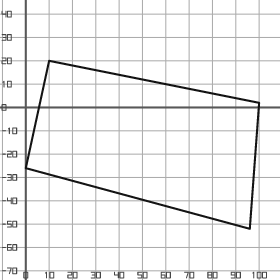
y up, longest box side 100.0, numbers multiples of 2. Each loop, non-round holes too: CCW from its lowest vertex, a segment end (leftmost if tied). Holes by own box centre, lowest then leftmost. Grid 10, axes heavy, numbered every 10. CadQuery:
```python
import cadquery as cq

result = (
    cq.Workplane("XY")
    .moveTo(96.0, -52.0)
    .lineTo(100.0, 2.0)
    .lineTo(10.0, 20.0)
    .lineTo(0.0, -26.0)
    .close()
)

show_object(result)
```